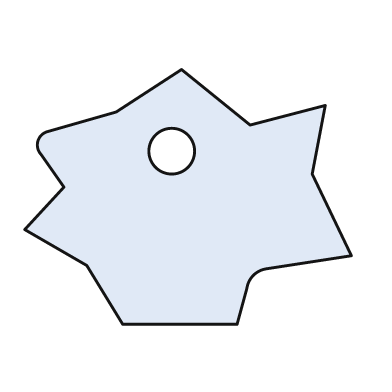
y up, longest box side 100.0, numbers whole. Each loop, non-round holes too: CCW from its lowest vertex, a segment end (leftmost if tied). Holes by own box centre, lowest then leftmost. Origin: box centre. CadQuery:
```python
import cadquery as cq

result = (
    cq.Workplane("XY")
    .moveTo(-20.0, -39.0)
    .lineTo(15.0, -39.0)
    .lineTo(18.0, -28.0)
    .threePointArc((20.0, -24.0), (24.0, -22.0))
    .lineTo(50.0, -18.0)
    .lineTo(38.0, 7.0)
    .lineTo(42.0, 28.0)
    .lineTo(19.0, 22.0)
    .lineTo(-2.0, 39.0)
    .lineTo(-22.0, 26.0)
    .lineTo(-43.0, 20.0)
    .threePointArc((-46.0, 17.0), (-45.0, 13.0))
    .lineTo(-38.0, 3.0)
    .lineTo(-50.0, -10.0)
    .lineTo(-31.0, -21.0)
    .close()
    .moveTo(-5.0, 14.0)
    .circle(7.0)
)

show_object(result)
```